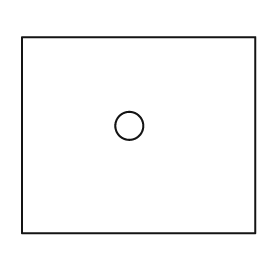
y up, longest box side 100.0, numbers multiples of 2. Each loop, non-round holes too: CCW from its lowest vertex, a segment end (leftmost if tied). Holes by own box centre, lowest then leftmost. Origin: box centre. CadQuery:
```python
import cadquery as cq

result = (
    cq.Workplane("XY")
    .moveTo(-50.0, -42.0)
    .lineTo(50.0, -42.0)
    .lineTo(50.0, 42.0)
    .lineTo(-50.0, 42.0)
    .close()
    .moveTo(-4.0, 4.0)
    .circle(6.0)
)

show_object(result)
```